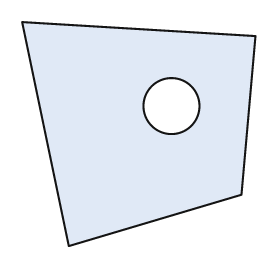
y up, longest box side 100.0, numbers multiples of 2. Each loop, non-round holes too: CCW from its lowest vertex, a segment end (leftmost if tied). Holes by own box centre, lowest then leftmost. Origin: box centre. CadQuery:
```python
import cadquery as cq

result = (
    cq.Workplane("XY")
    .moveTo(-30.0, -48.0)
    .lineTo(44.0, -26.0)
    .lineTo(50.0, 42.0)
    .lineTo(-50.0, 48.0)
    .close()
    .moveTo(14.0, 12.0)
    .circle(12.0)
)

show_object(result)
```